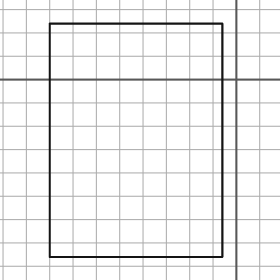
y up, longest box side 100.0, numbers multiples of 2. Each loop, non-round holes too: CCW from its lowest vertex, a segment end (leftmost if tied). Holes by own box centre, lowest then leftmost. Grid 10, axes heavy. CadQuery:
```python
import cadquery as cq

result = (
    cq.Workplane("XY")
    .moveTo(-80.0, -76.0)
    .lineTo(-6.0, -76.0)
    .lineTo(-6.0, 24.0)
    .lineTo(-80.0, 24.0)
    .close()
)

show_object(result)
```